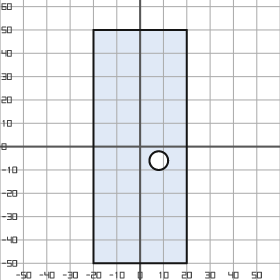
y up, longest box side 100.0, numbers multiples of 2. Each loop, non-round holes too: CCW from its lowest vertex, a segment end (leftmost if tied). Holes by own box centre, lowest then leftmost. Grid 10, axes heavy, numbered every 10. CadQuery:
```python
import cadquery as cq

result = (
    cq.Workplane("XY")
    .moveTo(-20.0, -50.0)
    .lineTo(20.0, -50.0)
    .lineTo(20.0, 50.0)
    .lineTo(-20.0, 50.0)
    .close()
    .moveTo(8.0, -6.0)
    .circle(4.0)
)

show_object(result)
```